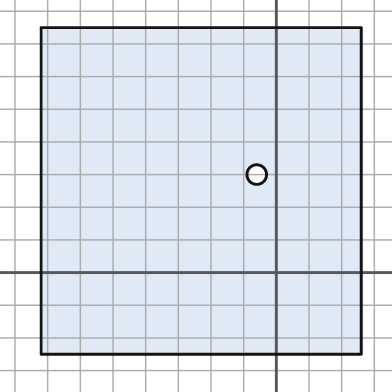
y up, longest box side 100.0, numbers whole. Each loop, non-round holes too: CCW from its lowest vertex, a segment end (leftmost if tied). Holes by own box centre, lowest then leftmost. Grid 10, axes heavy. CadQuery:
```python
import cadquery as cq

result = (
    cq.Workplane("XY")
    .moveTo(-72.0, -25.0)
    .lineTo(26.0, -25.0)
    .lineTo(26.0, 75.0)
    .lineTo(-72.0, 75.0)
    .close()
    .moveTo(-6.0, 30.0)
    .circle(3.0)
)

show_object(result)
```